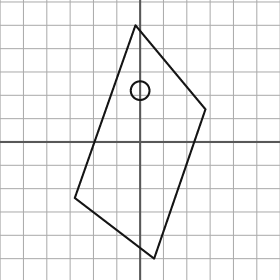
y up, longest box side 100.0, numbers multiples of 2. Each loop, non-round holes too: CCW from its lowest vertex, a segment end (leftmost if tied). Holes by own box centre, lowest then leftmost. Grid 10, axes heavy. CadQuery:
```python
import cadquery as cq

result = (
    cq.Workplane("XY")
    .moveTo(6.0, -50.0)
    .lineTo(28.0, 14.0)
    .lineTo(-2.0, 50.0)
    .lineTo(-28.0, -24.0)
    .close()
    .moveTo(0.0, 22.0)
    .circle(4.0)
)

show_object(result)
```